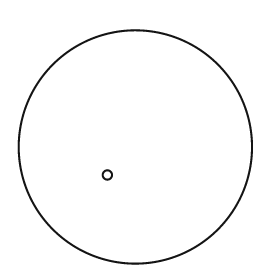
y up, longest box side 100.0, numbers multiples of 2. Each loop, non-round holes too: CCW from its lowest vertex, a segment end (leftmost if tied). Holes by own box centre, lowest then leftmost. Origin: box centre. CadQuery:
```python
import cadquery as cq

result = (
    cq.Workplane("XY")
    .moveTo(0.0, 0.0)
    .circle(50.0)
    .moveTo(-12.0, -12.0)
    .circle(2.0)
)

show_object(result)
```